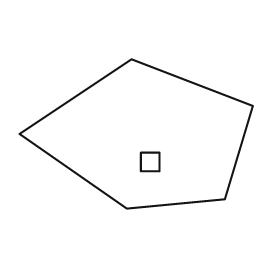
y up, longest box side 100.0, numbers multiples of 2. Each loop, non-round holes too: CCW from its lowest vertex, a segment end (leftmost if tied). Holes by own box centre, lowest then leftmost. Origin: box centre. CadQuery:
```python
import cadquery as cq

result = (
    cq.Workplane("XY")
    .moveTo(-4.0, -32.0)
    .lineTo(38.0, -28.0)
    .lineTo(50.0, 12.0)
    .lineTo(-2.0, 32.0)
    .lineTo(-50.0, 0.0)
    .close()
    .moveTo(2.0, -16.0)
    .lineTo(10.0, -16.0)
    .lineTo(10.0, -8.0)
    .lineTo(2.0, -8.0)
    .close()
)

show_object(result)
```